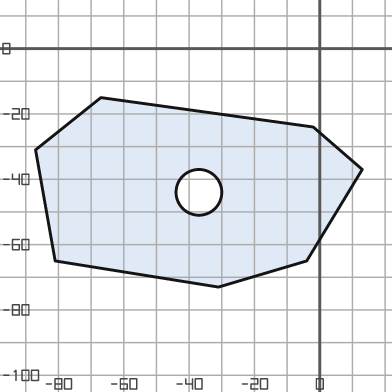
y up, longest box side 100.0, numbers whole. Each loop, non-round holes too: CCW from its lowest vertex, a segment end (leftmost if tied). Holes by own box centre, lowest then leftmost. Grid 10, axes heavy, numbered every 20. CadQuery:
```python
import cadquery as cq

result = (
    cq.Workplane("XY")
    .moveTo(-31.0, -73.0)
    .lineTo(-4.0, -65.0)
    .lineTo(13.0, -37.0)
    .lineTo(-2.0, -24.0)
    .lineTo(-67.0, -15.0)
    .lineTo(-87.0, -31.0)
    .lineTo(-81.0, -65.0)
    .close()
    .moveTo(-37.0, -44.0)
    .circle(7.0)
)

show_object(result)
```